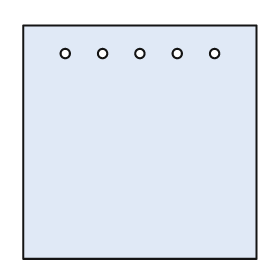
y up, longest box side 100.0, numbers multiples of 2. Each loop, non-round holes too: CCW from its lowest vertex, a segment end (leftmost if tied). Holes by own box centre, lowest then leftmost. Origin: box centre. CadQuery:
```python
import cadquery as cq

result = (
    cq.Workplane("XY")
    .moveTo(-50.0, -50.0)
    .lineTo(50.0, -50.0)
    .lineTo(50.0, 50.0)
    .lineTo(-50.0, 50.0)
    .close()
    .moveTo(-32.0, 38.0)
    .circle(2.0)
    .moveTo(-16.0, 38.0)
    .circle(2.0)
    .moveTo(0.0, 38.0)
    .circle(2.0)
    .moveTo(16.0, 38.0)
    .circle(2.0)
    .moveTo(32.0, 38.0)
    .circle(2.0)
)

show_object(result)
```